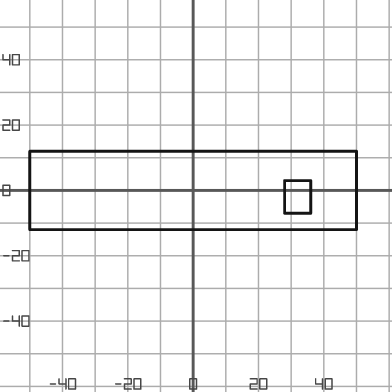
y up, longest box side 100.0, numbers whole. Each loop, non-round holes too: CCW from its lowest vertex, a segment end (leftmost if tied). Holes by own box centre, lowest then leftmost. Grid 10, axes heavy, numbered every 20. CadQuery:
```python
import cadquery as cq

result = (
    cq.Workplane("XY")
    .moveTo(-50.0, -12.0)
    .lineTo(50.0, -12.0)
    .lineTo(50.0, 12.0)
    .lineTo(-50.0, 12.0)
    .close()
    .moveTo(28.0, -7.0)
    .lineTo(36.0, -7.0)
    .lineTo(36.0, 3.0)
    .lineTo(28.0, 3.0)
    .close()
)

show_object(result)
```